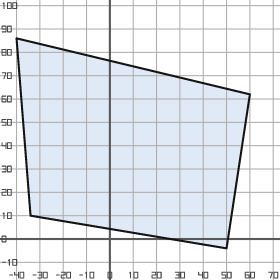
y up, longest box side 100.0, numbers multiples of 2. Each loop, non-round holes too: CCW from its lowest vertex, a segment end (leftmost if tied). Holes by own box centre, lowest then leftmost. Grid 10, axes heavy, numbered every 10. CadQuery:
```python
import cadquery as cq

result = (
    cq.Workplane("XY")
    .moveTo(50.0, -4.0)
    .lineTo(60.0, 62.0)
    .lineTo(-40.0, 86.0)
    .lineTo(-34.0, 10.0)
    .close()
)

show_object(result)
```